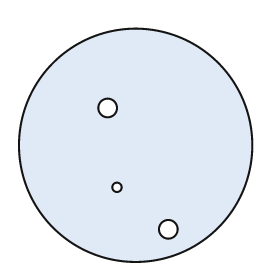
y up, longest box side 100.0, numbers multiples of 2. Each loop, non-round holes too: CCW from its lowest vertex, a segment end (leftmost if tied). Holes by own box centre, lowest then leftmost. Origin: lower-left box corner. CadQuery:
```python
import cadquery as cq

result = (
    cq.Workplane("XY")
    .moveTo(50.0, 50.0)
    .circle(50.0)
    .moveTo(64.0, 14.0)
    .circle(4.0)
    .moveTo(42.0, 32.0)
    .circle(2.0)
    .moveTo(38.0, 66.0)
    .circle(4.0)
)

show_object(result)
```